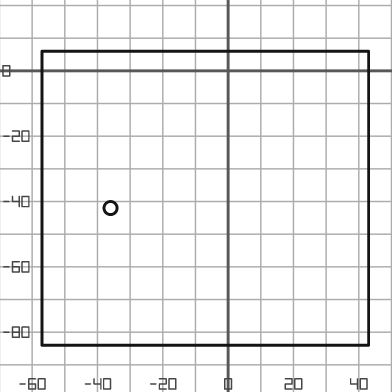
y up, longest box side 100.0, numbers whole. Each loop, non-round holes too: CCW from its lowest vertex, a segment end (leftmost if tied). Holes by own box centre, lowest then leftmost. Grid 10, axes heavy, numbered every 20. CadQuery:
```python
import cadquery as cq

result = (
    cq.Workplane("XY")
    .moveTo(-57.0, -84.0)
    .lineTo(43.0, -84.0)
    .lineTo(43.0, 6.0)
    .lineTo(-57.0, 6.0)
    .close()
    .moveTo(-36.0, -42.0)
    .circle(2.0)
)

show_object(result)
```